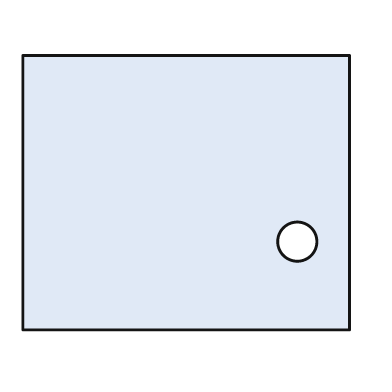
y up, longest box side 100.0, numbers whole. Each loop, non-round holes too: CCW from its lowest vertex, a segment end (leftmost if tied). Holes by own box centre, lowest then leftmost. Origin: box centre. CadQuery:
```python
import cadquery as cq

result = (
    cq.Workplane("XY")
    .moveTo(-50.0, -42.0)
    .lineTo(50.0, -42.0)
    .lineTo(50.0, 42.0)
    .lineTo(-50.0, 42.0)
    .close()
    .moveTo(34.0, -15.0)
    .circle(6.0)
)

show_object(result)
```